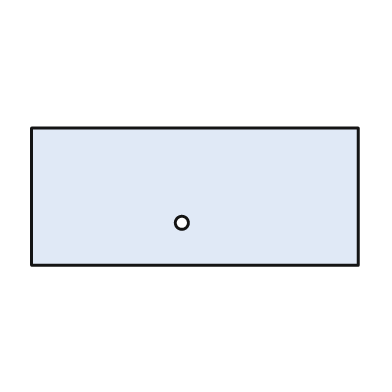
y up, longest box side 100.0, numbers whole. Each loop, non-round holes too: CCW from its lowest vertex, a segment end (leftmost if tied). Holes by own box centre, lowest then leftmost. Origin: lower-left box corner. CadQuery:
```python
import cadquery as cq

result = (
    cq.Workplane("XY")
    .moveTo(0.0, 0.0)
    .lineTo(100.0, 0.0)
    .lineTo(100.0, 42.0)
    .lineTo(0.0, 42.0)
    .close()
    .moveTo(46.0, 13.0)
    .circle(2.0)
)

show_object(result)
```